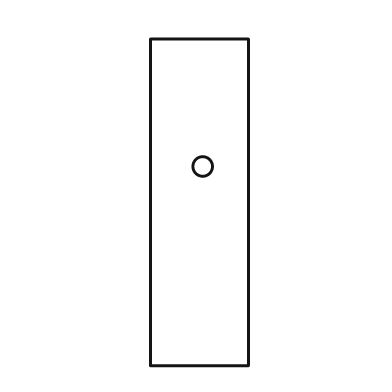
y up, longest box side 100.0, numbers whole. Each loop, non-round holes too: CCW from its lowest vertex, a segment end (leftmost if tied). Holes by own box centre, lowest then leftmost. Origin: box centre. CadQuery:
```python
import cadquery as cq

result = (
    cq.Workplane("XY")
    .moveTo(-15.0, -50.0)
    .lineTo(15.0, -50.0)
    .lineTo(15.0, 50.0)
    .lineTo(-15.0, 50.0)
    .close()
    .moveTo(1.0, 11.0)
    .circle(3.0)
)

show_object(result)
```